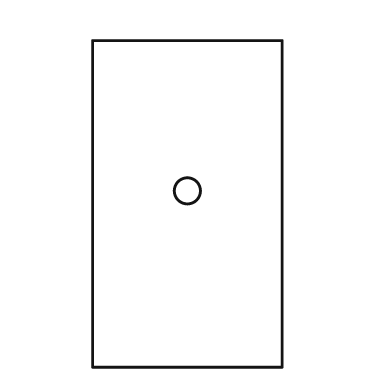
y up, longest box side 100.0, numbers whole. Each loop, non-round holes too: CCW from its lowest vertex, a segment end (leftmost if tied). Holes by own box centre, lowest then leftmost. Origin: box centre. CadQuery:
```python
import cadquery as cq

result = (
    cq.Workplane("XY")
    .moveTo(-29.0, -50.0)
    .lineTo(29.0, -50.0)
    .lineTo(29.0, 50.0)
    .lineTo(-29.0, 50.0)
    .close()
    .moveTo(0.0, 4.0)
    .circle(4.0)
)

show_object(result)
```